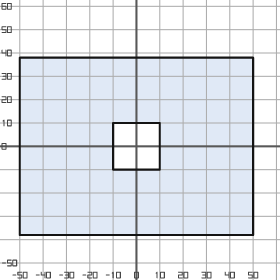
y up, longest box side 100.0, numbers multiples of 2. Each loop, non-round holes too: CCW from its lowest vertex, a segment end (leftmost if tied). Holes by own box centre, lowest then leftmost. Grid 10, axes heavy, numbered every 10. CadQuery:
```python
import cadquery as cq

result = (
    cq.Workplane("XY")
    .moveTo(-50.0, -38.0)
    .lineTo(50.0, -38.0)
    .lineTo(50.0, 38.0)
    .lineTo(-50.0, 38.0)
    .close()
    .moveTo(-10.0, -10.0)
    .lineTo(10.0, -10.0)
    .lineTo(10.0, 10.0)
    .lineTo(-10.0, 10.0)
    .close()
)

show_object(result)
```